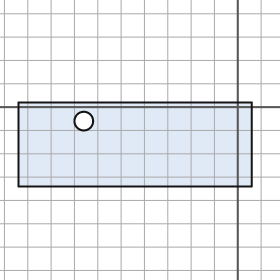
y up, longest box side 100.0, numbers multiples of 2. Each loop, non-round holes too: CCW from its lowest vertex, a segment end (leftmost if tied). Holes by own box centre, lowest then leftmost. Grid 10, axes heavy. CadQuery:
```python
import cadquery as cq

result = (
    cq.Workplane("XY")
    .moveTo(-94.0, -34.0)
    .lineTo(6.0, -34.0)
    .lineTo(6.0, 2.0)
    .lineTo(-94.0, 2.0)
    .close()
    .moveTo(-66.0, -6.0)
    .circle(4.0)
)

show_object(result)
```